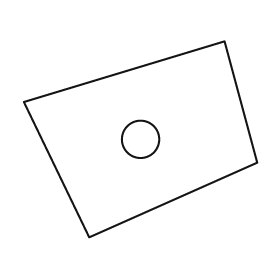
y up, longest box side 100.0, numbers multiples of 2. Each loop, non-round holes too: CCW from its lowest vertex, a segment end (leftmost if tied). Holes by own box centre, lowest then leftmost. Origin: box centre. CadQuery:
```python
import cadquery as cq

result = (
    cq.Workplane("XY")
    .moveTo(-22.0, -42.0)
    .lineTo(50.0, -10.0)
    .lineTo(36.0, 42.0)
    .lineTo(-50.0, 16.0)
    .close()
    .moveTo(0.0, 0.0)
    .circle(8.0)
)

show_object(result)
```